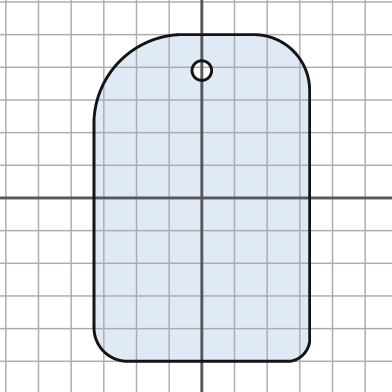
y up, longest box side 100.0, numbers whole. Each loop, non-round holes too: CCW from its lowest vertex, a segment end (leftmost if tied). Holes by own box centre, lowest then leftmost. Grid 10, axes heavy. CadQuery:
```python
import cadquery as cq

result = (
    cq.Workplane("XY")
    .moveTo(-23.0, -50.0)
    .lineTo(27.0, -50.0)
    .threePointArc((31.0, -48.0), (33.0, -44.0))
    .lineTo(33.0, 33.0)
    .threePointArc((28.0, 45.0), (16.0, 50.0))
    .lineTo(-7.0, 50.0)
    .threePointArc((-25.0, 42.0), (-33.0, 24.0))
    .lineTo(-33.0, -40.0)
    .threePointArc((-30.0, -47.0), (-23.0, -50.0))
    .close()
    .moveTo(0.0, 39.0)
    .circle(3.0)
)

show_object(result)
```